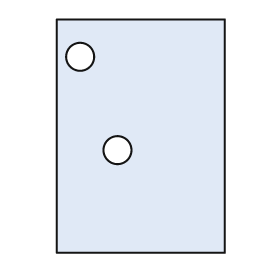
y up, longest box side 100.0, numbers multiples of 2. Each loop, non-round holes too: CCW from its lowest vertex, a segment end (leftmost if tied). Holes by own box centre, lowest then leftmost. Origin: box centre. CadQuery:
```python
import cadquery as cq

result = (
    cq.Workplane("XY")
    .moveTo(-36.0, -50.0)
    .lineTo(36.0, -50.0)
    .lineTo(36.0, 50.0)
    .lineTo(-36.0, 50.0)
    .close()
    .moveTo(-10.0, -6.0)
    .circle(6.0)
    .moveTo(-26.0, 34.0)
    .circle(6.0)
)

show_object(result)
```